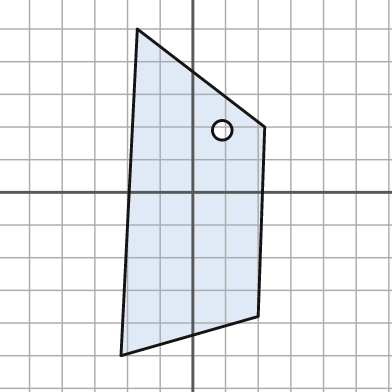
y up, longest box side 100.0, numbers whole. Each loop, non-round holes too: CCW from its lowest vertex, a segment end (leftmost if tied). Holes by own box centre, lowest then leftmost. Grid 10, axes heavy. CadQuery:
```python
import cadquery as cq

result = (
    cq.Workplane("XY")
    .moveTo(-22.0, -50.0)
    .lineTo(20.0, -38.0)
    .lineTo(22.0, 20.0)
    .lineTo(-17.0, 50.0)
    .close()
    .moveTo(9.0, 19.0)
    .circle(3.0)
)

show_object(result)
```